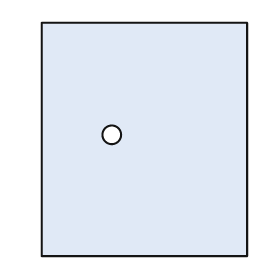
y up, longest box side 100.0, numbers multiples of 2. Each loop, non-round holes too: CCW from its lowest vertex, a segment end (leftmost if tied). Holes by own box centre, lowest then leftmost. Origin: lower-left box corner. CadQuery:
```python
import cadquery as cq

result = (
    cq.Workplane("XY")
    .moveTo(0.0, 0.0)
    .lineTo(88.0, 0.0)
    .lineTo(88.0, 100.0)
    .lineTo(0.0, 100.0)
    .close()
    .moveTo(30.0, 52.0)
    .circle(4.0)
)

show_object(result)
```